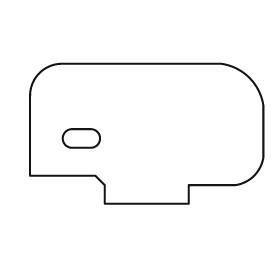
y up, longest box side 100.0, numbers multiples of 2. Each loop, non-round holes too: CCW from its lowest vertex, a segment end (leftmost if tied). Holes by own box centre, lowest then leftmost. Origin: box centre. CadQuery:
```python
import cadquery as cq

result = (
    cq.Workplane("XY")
    .moveTo(-18.0, -30.0)
    .lineTo(18.0, -30.0)
    .lineTo(18.0, -22.0)
    .lineTo(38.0, -22.0)
    .threePointArc((46.0, -18.0), (50.0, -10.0))
    .lineTo(50.0, 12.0)
    .threePointArc((44.0, 24.0), (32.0, 30.0))
    .lineTo(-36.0, 30.0)
    .threePointArc((-46.0, 26.0), (-50.0, 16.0))
    .lineTo(-50.0, -18.0)
    .lineTo(-22.0, -18.0)
    .lineTo(-18.0, -22.0)
    .close()
    .moveTo(-32.0, -6.0)
    .lineTo(-24.0, -6.0)
    .threePointArc((-20.0, -2.0), (-24.0, 2.0))
    .lineTo(-32.0, 2.0)
    .threePointArc((-36.0, -2.0), (-32.0, -6.0))
    .close()
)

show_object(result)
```